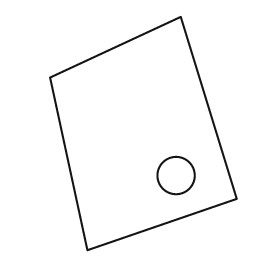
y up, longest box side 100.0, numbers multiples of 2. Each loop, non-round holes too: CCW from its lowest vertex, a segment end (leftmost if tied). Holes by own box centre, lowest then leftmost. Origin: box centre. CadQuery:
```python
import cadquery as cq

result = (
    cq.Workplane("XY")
    .moveTo(-24.0, -50.0)
    .lineTo(40.0, -28.0)
    .lineTo(16.0, 50.0)
    .lineTo(-40.0, 24.0)
    .close()
    .moveTo(14.0, -18.0)
    .circle(8.0)
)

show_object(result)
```